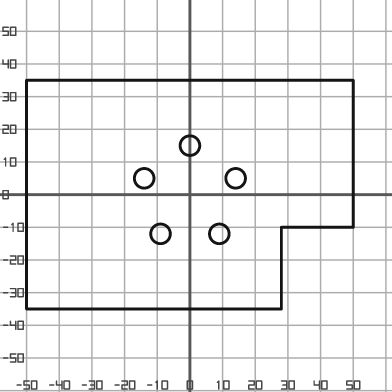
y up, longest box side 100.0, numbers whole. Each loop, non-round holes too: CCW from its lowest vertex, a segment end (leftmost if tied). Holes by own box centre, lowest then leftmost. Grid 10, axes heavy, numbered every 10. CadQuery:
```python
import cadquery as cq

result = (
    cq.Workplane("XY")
    .moveTo(-50.0, -35.0)
    .lineTo(28.0, -35.0)
    .lineTo(28.0, -10.0)
    .lineTo(50.0, -10.0)
    .lineTo(50.0, 35.0)
    .lineTo(-50.0, 35.0)
    .close()
    .moveTo(-9.0, -12.0)
    .circle(3.0)
    .moveTo(9.0, -12.0)
    .circle(3.0)
    .moveTo(-14.0, 5.0)
    .circle(3.0)
    .moveTo(14.0, 5.0)
    .circle(3.0)
    .moveTo(0.0, 15.0)
    .circle(3.0)
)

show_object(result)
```